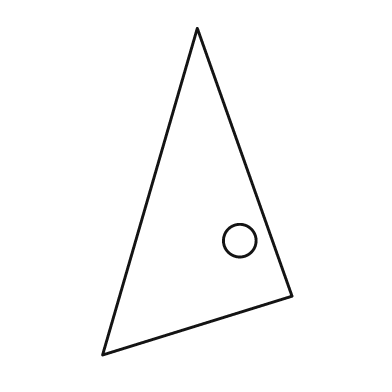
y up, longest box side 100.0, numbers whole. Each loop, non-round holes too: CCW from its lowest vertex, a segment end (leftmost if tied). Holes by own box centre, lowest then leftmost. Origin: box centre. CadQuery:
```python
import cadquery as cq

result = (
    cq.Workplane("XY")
    .moveTo(-29.0, -50.0)
    .lineTo(29.0, -32.0)
    .lineTo(0.0, 50.0)
    .close()
    .moveTo(13.0, -15.0)
    .circle(5.0)
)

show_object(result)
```